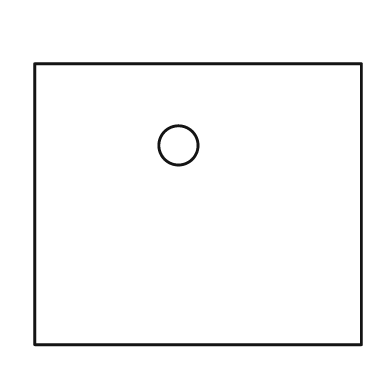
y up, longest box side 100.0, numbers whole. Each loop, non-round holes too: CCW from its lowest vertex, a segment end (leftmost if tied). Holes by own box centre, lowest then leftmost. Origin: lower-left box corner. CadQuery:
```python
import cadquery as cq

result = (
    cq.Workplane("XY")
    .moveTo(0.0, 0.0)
    .lineTo(100.0, 0.0)
    .lineTo(100.0, 86.0)
    .lineTo(0.0, 86.0)
    .close()
    .moveTo(44.0, 61.0)
    .circle(6.0)
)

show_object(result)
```